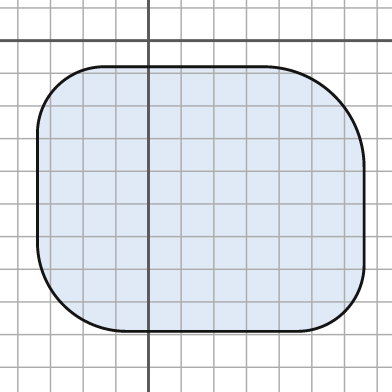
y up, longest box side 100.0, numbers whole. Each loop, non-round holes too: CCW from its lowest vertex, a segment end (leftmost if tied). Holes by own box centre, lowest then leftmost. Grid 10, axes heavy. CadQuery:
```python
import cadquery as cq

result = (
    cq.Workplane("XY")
    .moveTo(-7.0, -89.0)
    .lineTo(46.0, -89.0)
    .threePointArc((60.0, -83.0), (66.0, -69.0))
    .lineTo(66.0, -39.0)
    .threePointArc((57.0, -17.0), (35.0, -8.0))
    .lineTo(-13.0, -8.0)
    .threePointArc((-28.0, -14.0), (-34.0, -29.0))
    .lineTo(-34.0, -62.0)
    .threePointArc((-26.0, -81.0), (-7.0, -89.0))
    .close()
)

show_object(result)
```